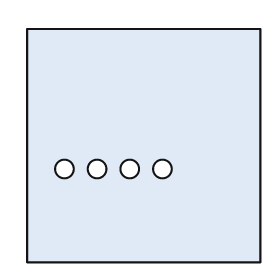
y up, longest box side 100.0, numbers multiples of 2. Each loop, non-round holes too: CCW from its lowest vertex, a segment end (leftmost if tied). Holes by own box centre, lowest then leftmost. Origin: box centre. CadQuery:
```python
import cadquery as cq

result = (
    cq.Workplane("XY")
    .moveTo(-50.0, -50.0)
    .lineTo(50.0, -50.0)
    .lineTo(50.0, 50.0)
    .lineTo(-50.0, 50.0)
    .close()
    .moveTo(-34.0, -10.0)
    .circle(4.0)
    .moveTo(-20.0, -10.0)
    .circle(4.0)
    .moveTo(-6.0, -10.0)
    .circle(4.0)
    .moveTo(8.0, -10.0)
    .circle(4.0)
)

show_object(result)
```